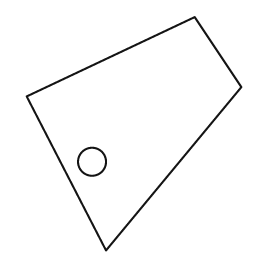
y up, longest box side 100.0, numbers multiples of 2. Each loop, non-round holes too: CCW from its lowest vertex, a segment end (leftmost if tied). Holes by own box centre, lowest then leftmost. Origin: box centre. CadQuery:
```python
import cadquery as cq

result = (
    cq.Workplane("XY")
    .moveTo(-12.0, -50.0)
    .lineTo(46.0, 20.0)
    .lineTo(26.0, 50.0)
    .lineTo(-46.0, 16.0)
    .close()
    .moveTo(-18.0, -12.0)
    .circle(6.0)
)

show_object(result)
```